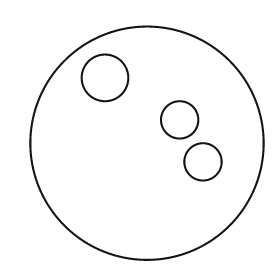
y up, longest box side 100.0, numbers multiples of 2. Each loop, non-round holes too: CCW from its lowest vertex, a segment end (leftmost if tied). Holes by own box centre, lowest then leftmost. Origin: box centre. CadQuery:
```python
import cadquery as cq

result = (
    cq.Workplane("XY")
    .moveTo(0.0, 0.0)
    .circle(50.0)
    .moveTo(24.0, -8.0)
    .circle(8.0)
    .moveTo(14.0, 10.0)
    .circle(8.0)
    .moveTo(-18.0, 28.0)
    .circle(10.0)
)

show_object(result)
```